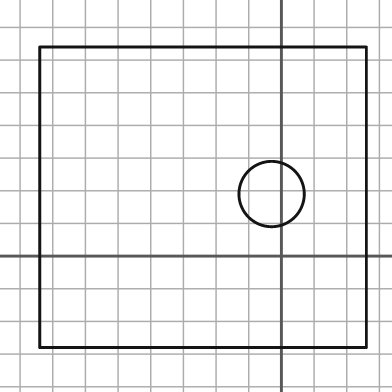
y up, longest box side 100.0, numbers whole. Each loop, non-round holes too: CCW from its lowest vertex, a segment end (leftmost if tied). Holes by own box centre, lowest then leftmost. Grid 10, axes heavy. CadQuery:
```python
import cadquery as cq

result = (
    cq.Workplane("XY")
    .moveTo(-74.0, -28.0)
    .lineTo(26.0, -28.0)
    .lineTo(26.0, 64.0)
    .lineTo(-74.0, 64.0)
    .close()
    .moveTo(-3.0, 19.0)
    .circle(10.0)
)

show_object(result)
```